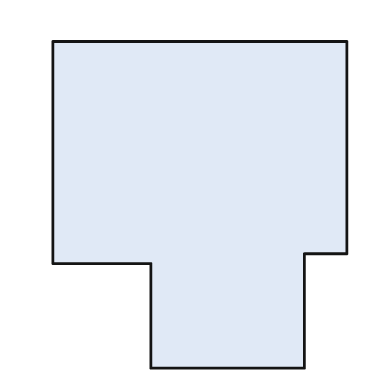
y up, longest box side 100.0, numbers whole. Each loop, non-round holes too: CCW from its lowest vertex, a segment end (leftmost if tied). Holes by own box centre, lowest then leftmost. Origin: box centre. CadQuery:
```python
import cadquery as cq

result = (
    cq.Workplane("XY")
    .moveTo(-15.0, -50.0)
    .lineTo(32.0, -50.0)
    .lineTo(32.0, -15.0)
    .lineTo(45.0, -15.0)
    .lineTo(45.0, 50.0)
    .lineTo(-45.0, 50.0)
    .lineTo(-45.0, -18.0)
    .lineTo(-15.0, -18.0)
    .close()
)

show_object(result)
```